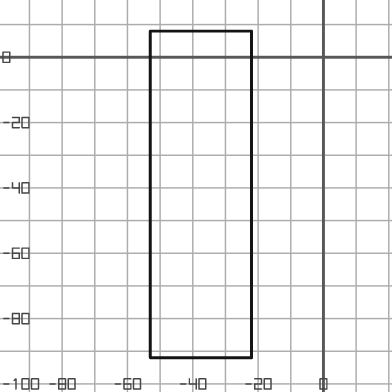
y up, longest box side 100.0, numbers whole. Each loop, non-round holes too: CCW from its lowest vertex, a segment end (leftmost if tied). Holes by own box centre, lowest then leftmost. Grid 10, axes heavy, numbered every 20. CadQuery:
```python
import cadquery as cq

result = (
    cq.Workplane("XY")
    .moveTo(-53.0, -92.0)
    .lineTo(-22.0, -92.0)
    .lineTo(-22.0, 8.0)
    .lineTo(-53.0, 8.0)
    .close()
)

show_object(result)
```